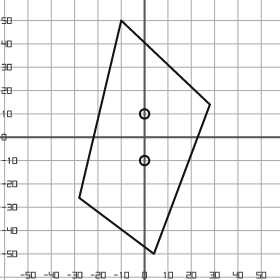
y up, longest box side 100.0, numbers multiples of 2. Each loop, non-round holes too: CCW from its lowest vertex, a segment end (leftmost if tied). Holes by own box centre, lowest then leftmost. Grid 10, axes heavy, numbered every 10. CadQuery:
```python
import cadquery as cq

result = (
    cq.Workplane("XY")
    .moveTo(4.0, -50.0)
    .lineTo(28.0, 14.0)
    .lineTo(-10.0, 50.0)
    .lineTo(-28.0, -26.0)
    .close()
    .moveTo(0.0, -10.0)
    .circle(2.0)
    .moveTo(0.0, 10.0)
    .circle(2.0)
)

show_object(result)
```